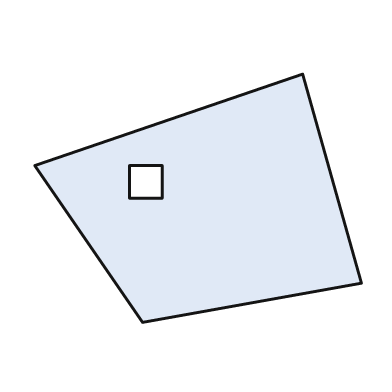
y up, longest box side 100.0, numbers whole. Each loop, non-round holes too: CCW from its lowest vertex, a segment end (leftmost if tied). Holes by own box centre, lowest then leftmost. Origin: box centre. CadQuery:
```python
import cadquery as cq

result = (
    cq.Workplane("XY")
    .moveTo(-17.0, -38.0)
    .lineTo(50.0, -26.0)
    .lineTo(32.0, 38.0)
    .lineTo(-50.0, 10.0)
    .close()
    .moveTo(-21.0, 0.0)
    .lineTo(-11.0, 0.0)
    .lineTo(-11.0, 10.0)
    .lineTo(-21.0, 10.0)
    .close()
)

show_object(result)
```